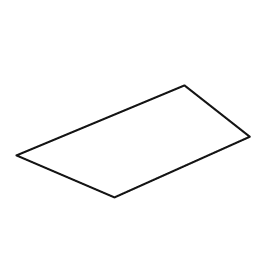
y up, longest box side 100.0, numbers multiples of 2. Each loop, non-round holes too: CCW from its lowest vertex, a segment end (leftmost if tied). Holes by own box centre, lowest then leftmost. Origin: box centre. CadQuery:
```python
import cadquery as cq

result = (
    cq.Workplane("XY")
    .moveTo(-8.0, -24.0)
    .lineTo(50.0, 2.0)
    .lineTo(22.0, 24.0)
    .lineTo(-50.0, -6.0)
    .close()
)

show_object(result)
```